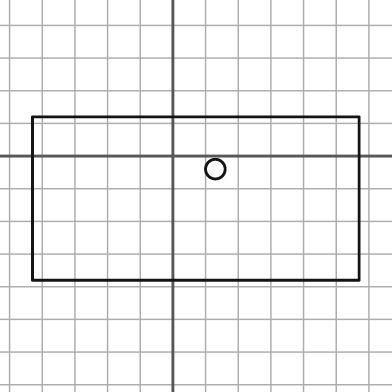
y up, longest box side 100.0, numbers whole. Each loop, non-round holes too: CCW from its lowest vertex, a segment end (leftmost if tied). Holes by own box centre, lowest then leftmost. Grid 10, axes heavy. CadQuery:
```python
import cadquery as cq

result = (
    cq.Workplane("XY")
    .moveTo(-43.0, -38.0)
    .lineTo(57.0, -38.0)
    .lineTo(57.0, 12.0)
    .lineTo(-43.0, 12.0)
    .close()
    .moveTo(13.0, -4.0)
    .circle(3.0)
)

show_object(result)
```